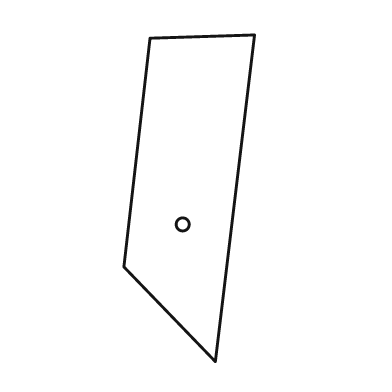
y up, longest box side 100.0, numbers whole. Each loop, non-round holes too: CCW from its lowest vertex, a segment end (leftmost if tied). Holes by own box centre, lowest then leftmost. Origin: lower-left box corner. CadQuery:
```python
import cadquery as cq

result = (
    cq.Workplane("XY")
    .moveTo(28.0, 0.0)
    .lineTo(40.0, 100.0)
    .lineTo(8.0, 99.0)
    .lineTo(0.0, 29.0)
    .close()
    .moveTo(18.0, 42.0)
    .circle(2.0)
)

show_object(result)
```